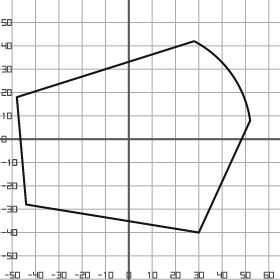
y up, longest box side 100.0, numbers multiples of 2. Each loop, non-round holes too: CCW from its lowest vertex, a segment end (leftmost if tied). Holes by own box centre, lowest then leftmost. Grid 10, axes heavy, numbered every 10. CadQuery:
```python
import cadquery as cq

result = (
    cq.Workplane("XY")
    .moveTo(30.0, -40.0)
    .lineTo(52.0, 8.0)
    .threePointArc((44.0, 28.0), (28.0, 42.0))
    .lineTo(-48.0, 18.0)
    .lineTo(-44.0, -28.0)
    .close()
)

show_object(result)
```